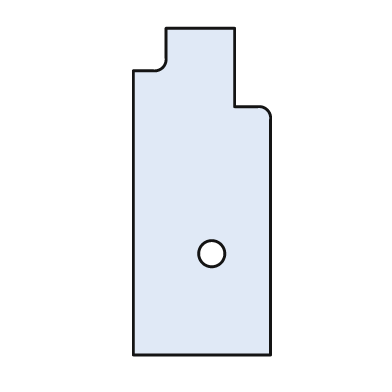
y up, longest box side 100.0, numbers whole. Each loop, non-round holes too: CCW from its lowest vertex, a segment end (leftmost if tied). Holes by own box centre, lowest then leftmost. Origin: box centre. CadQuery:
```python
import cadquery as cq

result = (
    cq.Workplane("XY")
    .moveTo(-21.0, -50.0)
    .lineTo(21.0, -50.0)
    .lineTo(21.0, 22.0)
    .threePointArc((20.0, 25.0), (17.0, 26.0))
    .lineTo(10.0, 26.0)
    .lineTo(10.0, 50.0)
    .lineTo(-11.0, 50.0)
    .lineTo(-11.0, 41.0)
    .threePointArc((-12.0, 38.0), (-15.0, 37.0))
    .lineTo(-21.0, 37.0)
    .close()
    .moveTo(3.0, -19.0)
    .circle(4.0)
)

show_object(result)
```